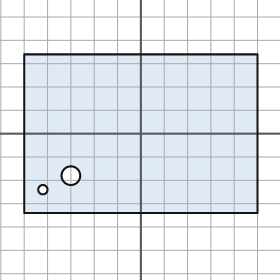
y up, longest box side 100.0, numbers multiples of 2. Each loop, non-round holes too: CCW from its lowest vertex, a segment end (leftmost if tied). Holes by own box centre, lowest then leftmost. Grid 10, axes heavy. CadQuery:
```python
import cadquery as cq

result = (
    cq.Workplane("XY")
    .moveTo(-50.0, -34.0)
    .lineTo(50.0, -34.0)
    .lineTo(50.0, 34.0)
    .lineTo(-50.0, 34.0)
    .close()
    .moveTo(-42.0, -24.0)
    .circle(2.0)
    .moveTo(-30.0, -18.0)
    .circle(4.0)
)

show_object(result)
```